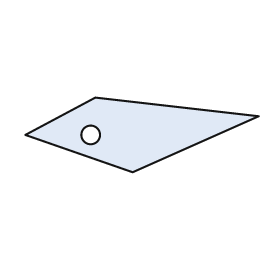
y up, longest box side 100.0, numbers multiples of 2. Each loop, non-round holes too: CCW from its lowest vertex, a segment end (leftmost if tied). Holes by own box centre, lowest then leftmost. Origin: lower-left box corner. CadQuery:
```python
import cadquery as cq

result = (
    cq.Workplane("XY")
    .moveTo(46.0, 0.0)
    .lineTo(100.0, 24.0)
    .lineTo(30.0, 32.0)
    .lineTo(0.0, 16.0)
    .close()
    .moveTo(28.0, 16.0)
    .circle(4.0)
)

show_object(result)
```